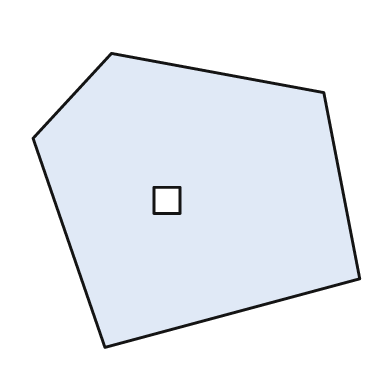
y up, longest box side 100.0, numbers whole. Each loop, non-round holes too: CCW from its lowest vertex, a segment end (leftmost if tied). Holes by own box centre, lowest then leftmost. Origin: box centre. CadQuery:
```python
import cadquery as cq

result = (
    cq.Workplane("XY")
    .moveTo(-28.0, -45.0)
    .lineTo(50.0, -24.0)
    .lineTo(39.0, 33.0)
    .lineTo(-26.0, 45.0)
    .lineTo(-50.0, 19.0)
    .close()
    .moveTo(-13.0, -4.0)
    .lineTo(-5.0, -4.0)
    .lineTo(-5.0, 4.0)
    .lineTo(-13.0, 4.0)
    .close()
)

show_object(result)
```